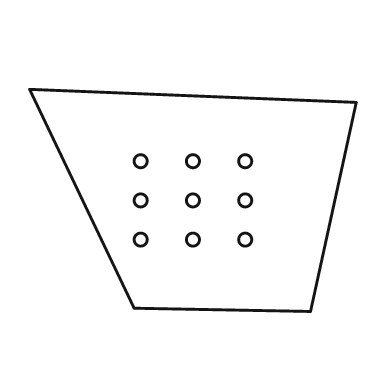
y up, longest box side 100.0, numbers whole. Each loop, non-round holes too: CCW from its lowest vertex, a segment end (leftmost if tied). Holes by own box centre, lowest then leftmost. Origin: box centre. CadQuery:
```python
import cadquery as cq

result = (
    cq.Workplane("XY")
    .moveTo(36.0, -34.0)
    .lineTo(50.0, 30.0)
    .lineTo(-50.0, 34.0)
    .lineTo(-18.0, -33.0)
    .close()
    .moveTo(-16.0, -12.0)
    .circle(2.0)
    .moveTo(0.0, -12.0)
    .circle(2.0)
    .moveTo(16.0, -12.0)
    .circle(2.0)
    .moveTo(-16.0, 0.0)
    .circle(2.0)
    .moveTo(0.0, 0.0)
    .circle(2.0)
    .moveTo(16.0, 0.0)
    .circle(2.0)
    .moveTo(-16.0, 12.0)
    .circle(2.0)
    .moveTo(0.0, 12.0)
    .circle(2.0)
    .moveTo(16.0, 12.0)
    .circle(2.0)
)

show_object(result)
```